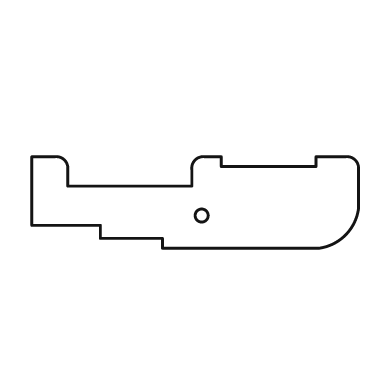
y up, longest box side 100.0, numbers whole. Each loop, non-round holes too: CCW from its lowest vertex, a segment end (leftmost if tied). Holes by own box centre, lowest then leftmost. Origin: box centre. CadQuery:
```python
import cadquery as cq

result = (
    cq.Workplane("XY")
    .moveTo(-10.0, -14.0)
    .lineTo(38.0, -14.0)
    .threePointArc((46.0, -10.0), (50.0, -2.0))
    .lineTo(50.0, 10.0)
    .threePointArc((49.0, 13.0), (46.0, 14.0))
    .lineTo(37.0, 14.0)
    .lineTo(37.0, 11.0)
    .lineTo(8.0, 11.0)
    .lineTo(8.0, 14.0)
    .lineTo(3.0, 14.0)
    .threePointArc((0.0, 13.0), (-1.0, 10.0))
    .lineTo(-1.0, 5.0)
    .lineTo(-39.0, 5.0)
    .lineTo(-39.0, 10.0)
    .threePointArc((-40.0, 13.0), (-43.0, 14.0))
    .lineTo(-50.0, 14.0)
    .lineTo(-50.0, -7.0)
    .lineTo(-29.0, -7.0)
    .lineTo(-29.0, -11.0)
    .lineTo(-10.0, -11.0)
    .close()
    .moveTo(2.0, -4.0)
    .circle(2.0)
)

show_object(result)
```